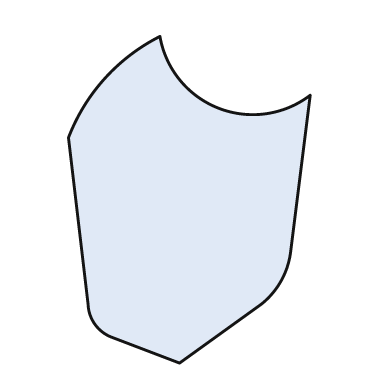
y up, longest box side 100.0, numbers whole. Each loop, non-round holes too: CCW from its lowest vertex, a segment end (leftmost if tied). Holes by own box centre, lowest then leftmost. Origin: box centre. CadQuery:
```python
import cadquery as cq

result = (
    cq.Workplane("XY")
    .moveTo(-3.0, -50.0)
    .lineTo(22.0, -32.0)
    .threePointArc((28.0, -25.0), (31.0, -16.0))
    .lineTo(37.0, 32.0)
    .threePointArc((9.0, 28.0), (-9.0, 50.0))
    .threePointArc((-26.0, 37.0), (-37.0, 19.0))
    .lineTo(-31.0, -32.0)
    .threePointArc((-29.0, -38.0), (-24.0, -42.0))
    .close()
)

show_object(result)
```